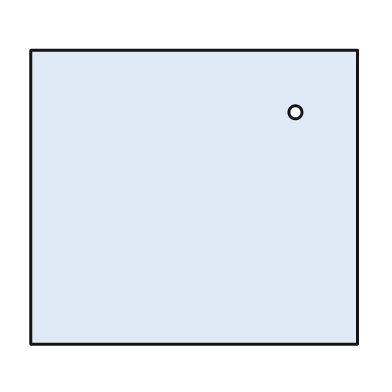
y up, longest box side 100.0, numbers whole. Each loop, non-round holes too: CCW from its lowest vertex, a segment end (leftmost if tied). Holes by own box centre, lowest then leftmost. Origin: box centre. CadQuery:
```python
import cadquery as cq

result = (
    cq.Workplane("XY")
    .moveTo(-50.0, -45.0)
    .lineTo(50.0, -45.0)
    .lineTo(50.0, 45.0)
    .lineTo(-50.0, 45.0)
    .close()
    .moveTo(31.0, 26.0)
    .circle(2.0)
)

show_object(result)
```